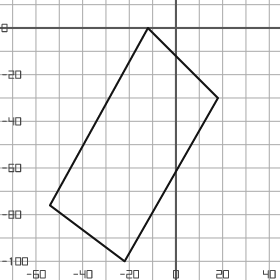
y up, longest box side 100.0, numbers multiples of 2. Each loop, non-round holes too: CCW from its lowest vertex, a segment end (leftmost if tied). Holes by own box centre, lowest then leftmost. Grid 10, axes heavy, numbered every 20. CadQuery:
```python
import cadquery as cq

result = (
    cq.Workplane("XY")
    .moveTo(-22.0, -100.0)
    .lineTo(18.0, -30.0)
    .lineTo(-12.0, 0.0)
    .lineTo(-54.0, -76.0)
    .close()
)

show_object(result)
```